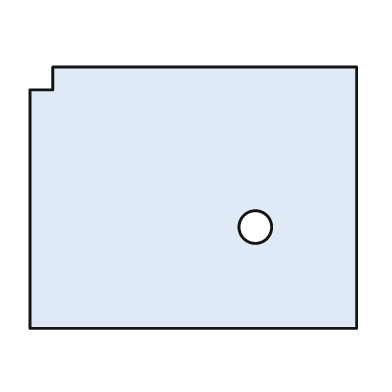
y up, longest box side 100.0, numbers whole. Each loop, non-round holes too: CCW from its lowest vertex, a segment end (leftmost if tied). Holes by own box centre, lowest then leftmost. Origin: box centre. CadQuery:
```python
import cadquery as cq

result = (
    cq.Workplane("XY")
    .moveTo(-50.0, -40.0)
    .lineTo(50.0, -40.0)
    .lineTo(50.0, 40.0)
    .lineTo(-43.0, 40.0)
    .lineTo(-43.0, 33.0)
    .lineTo(-50.0, 33.0)
    .close()
    .moveTo(19.0, -9.0)
    .circle(5.0)
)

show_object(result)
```